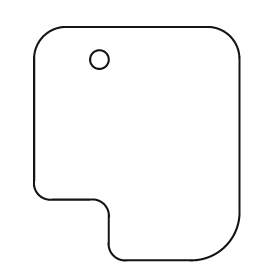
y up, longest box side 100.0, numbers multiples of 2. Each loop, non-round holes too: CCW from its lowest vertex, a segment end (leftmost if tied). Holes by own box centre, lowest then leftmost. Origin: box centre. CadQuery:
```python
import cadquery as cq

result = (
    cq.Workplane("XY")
    .moveTo(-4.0, -50.0)
    .lineTo(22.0, -50.0)
    .threePointArc((38.0, -44.0), (44.0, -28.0))
    .lineTo(44.0, 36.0)
    .threePointArc((40.0, 46.0), (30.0, 50.0))
    .lineTo(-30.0, 50.0)
    .threePointArc((-40.0, 46.0), (-44.0, 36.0))
    .lineTo(-44.0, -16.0)
    .threePointArc((-42.0, -22.0), (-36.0, -24.0))
    .lineTo(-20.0, -24.0)
    .threePointArc((-14.0, -26.0), (-12.0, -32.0))
    .lineTo(-12.0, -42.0)
    .threePointArc((-10.0, -48.0), (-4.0, -50.0))
    .close()
    .moveTo(-16.0, 36.0)
    .circle(4.0)
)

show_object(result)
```